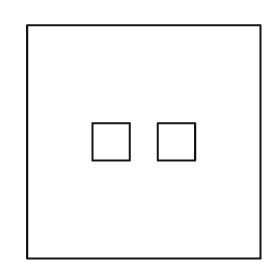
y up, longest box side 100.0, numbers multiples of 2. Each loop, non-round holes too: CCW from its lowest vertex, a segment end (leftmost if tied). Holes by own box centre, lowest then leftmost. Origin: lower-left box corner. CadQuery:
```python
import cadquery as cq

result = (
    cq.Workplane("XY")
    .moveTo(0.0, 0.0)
    .lineTo(100.0, 0.0)
    .lineTo(100.0, 100.0)
    .lineTo(0.0, 100.0)
    .close()
    .moveTo(28.0, 42.0)
    .lineTo(44.0, 42.0)
    .lineTo(44.0, 58.0)
    .lineTo(28.0, 58.0)
    .close()
    .moveTo(56.0, 42.0)
    .lineTo(72.0, 42.0)
    .lineTo(72.0, 58.0)
    .lineTo(56.0, 58.0)
    .close()
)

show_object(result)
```